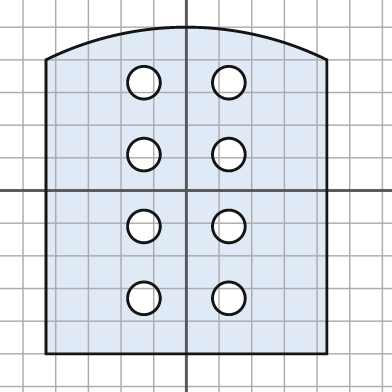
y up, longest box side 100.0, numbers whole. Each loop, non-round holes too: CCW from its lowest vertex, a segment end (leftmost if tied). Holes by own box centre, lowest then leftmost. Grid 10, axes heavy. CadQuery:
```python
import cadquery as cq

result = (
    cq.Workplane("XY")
    .moveTo(-43.0, -50.0)
    .lineTo(43.0, -50.0)
    .lineTo(43.0, 40.0)
    .threePointArc((0.0, 50.0), (-43.0, 40.0))
    .close()
    .moveTo(-13.0, -33.0)
    .circle(5.0)
    .moveTo(13.0, -33.0)
    .circle(5.0)
    .moveTo(-13.0, -11.0)
    .circle(5.0)
    .moveTo(13.0, -11.0)
    .circle(5.0)
    .moveTo(-13.0, 11.0)
    .circle(5.0)
    .moveTo(13.0, 11.0)
    .circle(5.0)
    .moveTo(-13.0, 33.0)
    .circle(5.0)
    .moveTo(13.0, 33.0)
    .circle(5.0)
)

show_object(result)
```